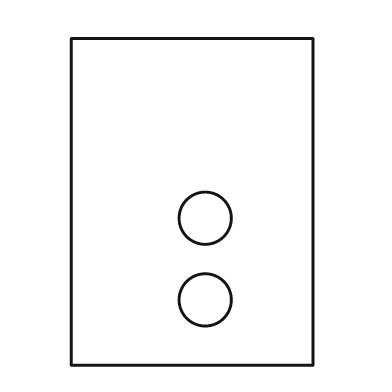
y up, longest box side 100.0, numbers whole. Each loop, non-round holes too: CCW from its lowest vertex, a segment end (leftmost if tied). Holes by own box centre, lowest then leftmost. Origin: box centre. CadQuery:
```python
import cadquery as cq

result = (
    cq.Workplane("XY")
    .moveTo(-37.0, -50.0)
    .lineTo(37.0, -50.0)
    .lineTo(37.0, 50.0)
    .lineTo(-37.0, 50.0)
    .close()
    .moveTo(4.0, -30.0)
    .circle(8.0)
    .moveTo(4.0, -5.0)
    .circle(8.0)
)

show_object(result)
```